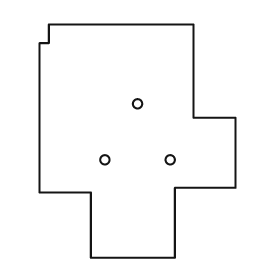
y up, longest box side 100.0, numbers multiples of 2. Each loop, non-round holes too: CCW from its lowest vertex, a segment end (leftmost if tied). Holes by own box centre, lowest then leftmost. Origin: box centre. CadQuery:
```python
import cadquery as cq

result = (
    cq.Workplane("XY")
    .moveTo(-20.0, -50.0)
    .lineTo(16.0, -50.0)
    .lineTo(16.0, -20.0)
    .lineTo(42.0, -20.0)
    .lineTo(42.0, 10.0)
    .lineTo(24.0, 10.0)
    .lineTo(24.0, 50.0)
    .lineTo(-38.0, 50.0)
    .lineTo(-38.0, 42.0)
    .lineTo(-42.0, 42.0)
    .lineTo(-42.0, -22.0)
    .lineTo(-20.0, -22.0)
    .close()
    .moveTo(-14.0, -8.0)
    .circle(2.0)
    .moveTo(14.0, -8.0)
    .circle(2.0)
    .moveTo(0.0, 16.0)
    .circle(2.0)
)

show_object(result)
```